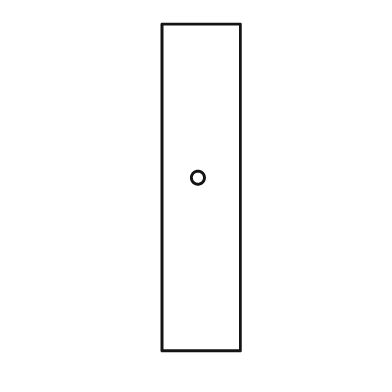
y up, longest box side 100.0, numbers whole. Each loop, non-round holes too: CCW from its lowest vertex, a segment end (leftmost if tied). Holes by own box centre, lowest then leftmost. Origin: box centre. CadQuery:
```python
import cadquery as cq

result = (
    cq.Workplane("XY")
    .moveTo(-12.0, -50.0)
    .lineTo(12.0, -50.0)
    .lineTo(12.0, 50.0)
    .lineTo(-12.0, 50.0)
    .close()
    .moveTo(-1.0, 3.0)
    .circle(2.0)
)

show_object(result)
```